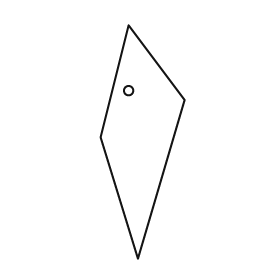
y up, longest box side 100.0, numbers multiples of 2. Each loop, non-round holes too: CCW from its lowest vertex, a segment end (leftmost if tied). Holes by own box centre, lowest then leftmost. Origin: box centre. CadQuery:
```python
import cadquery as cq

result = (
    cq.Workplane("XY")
    .moveTo(-2.0, -50.0)
    .lineTo(18.0, 18.0)
    .lineTo(-6.0, 50.0)
    .lineTo(-18.0, 2.0)
    .close()
    .moveTo(-6.0, 22.0)
    .circle(2.0)
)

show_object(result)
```